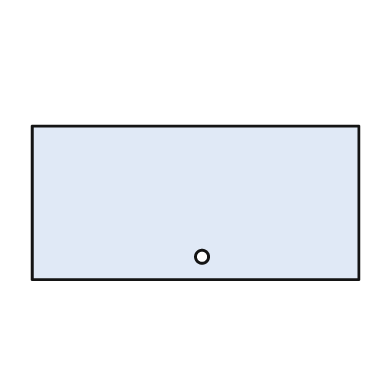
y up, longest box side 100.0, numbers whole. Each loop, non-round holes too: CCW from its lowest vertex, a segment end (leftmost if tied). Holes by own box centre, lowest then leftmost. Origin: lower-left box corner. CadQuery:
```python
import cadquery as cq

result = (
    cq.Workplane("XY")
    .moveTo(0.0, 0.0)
    .lineTo(100.0, 0.0)
    .lineTo(100.0, 47.0)
    .lineTo(0.0, 47.0)
    .close()
    .moveTo(52.0, 7.0)
    .circle(2.0)
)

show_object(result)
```